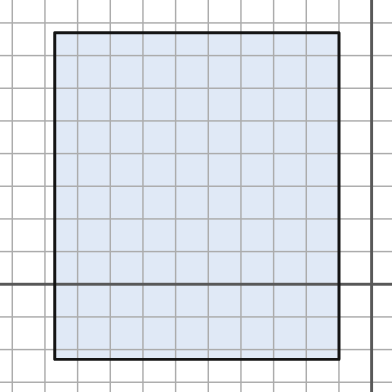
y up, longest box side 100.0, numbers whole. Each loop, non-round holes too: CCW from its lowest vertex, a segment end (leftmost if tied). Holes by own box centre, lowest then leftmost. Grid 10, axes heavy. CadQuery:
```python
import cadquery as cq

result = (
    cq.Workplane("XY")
    .moveTo(-97.0, -23.0)
    .lineTo(-10.0, -23.0)
    .lineTo(-10.0, 77.0)
    .lineTo(-97.0, 77.0)
    .close()
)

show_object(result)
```